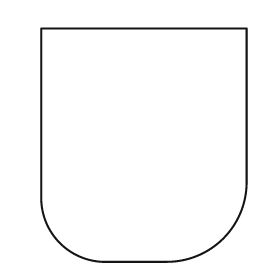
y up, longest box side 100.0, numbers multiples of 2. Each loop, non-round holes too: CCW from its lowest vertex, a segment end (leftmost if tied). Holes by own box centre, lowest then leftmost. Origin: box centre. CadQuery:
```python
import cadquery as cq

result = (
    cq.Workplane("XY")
    .moveTo(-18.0, -50.0)
    .lineTo(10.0, -50.0)
    .threePointArc((34.0, -40.0), (44.0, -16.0))
    .lineTo(44.0, 50.0)
    .lineTo(-44.0, 50.0)
    .lineTo(-44.0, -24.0)
    .threePointArc((-36.0, -42.0), (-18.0, -50.0))
    .close()
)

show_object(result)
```